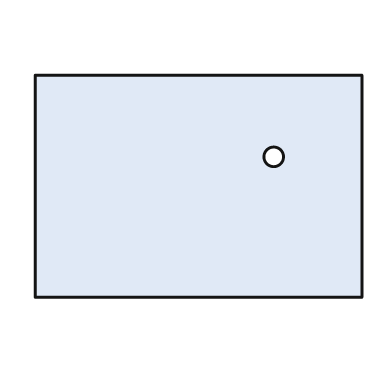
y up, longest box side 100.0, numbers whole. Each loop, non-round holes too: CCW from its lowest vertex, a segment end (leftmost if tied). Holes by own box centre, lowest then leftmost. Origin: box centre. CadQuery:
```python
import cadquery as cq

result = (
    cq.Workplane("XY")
    .moveTo(-50.0, -34.0)
    .lineTo(50.0, -34.0)
    .lineTo(50.0, 34.0)
    .lineTo(-50.0, 34.0)
    .close()
    .moveTo(23.0, 9.0)
    .circle(3.0)
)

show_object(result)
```